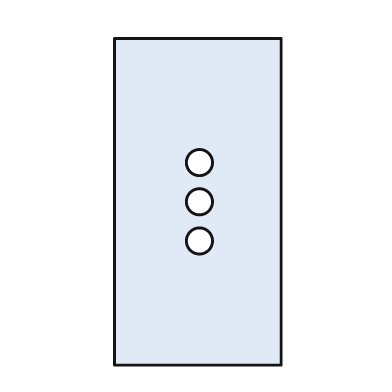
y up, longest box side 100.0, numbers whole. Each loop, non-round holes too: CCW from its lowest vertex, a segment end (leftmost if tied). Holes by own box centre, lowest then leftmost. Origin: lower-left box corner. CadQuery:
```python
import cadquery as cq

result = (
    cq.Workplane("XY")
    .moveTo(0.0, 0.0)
    .lineTo(51.0, 0.0)
    .lineTo(51.0, 100.0)
    .lineTo(0.0, 100.0)
    .close()
    .moveTo(26.0, 38.0)
    .circle(4.0)
    .moveTo(26.0, 50.0)
    .circle(4.0)
    .moveTo(26.0, 62.0)
    .circle(4.0)
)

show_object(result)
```